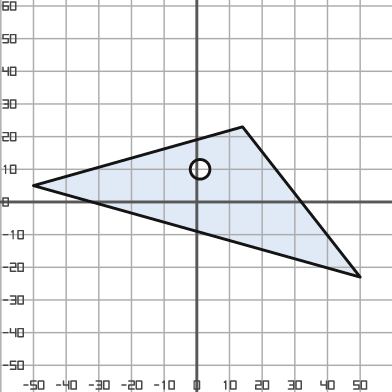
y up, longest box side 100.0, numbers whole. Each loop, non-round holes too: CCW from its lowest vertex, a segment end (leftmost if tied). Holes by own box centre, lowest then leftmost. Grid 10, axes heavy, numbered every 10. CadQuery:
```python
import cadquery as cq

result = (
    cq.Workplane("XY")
    .moveTo(50.0, -23.0)
    .lineTo(14.0, 23.0)
    .lineTo(-50.0, 5.0)
    .close()
    .moveTo(1.0, 10.0)
    .circle(3.0)
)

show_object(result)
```